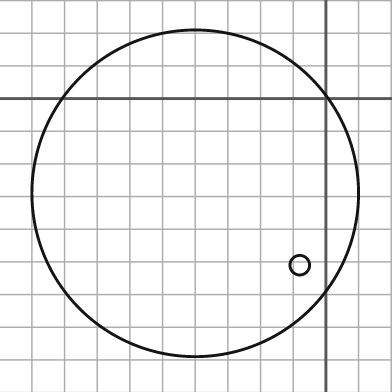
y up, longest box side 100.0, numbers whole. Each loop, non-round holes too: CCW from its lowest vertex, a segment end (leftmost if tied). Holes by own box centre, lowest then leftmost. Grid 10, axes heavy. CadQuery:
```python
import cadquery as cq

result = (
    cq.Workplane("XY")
    .moveTo(-40.0, -29.0)
    .circle(50.0)
    .moveTo(-8.0, -51.0)
    .circle(3.0)
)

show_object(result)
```